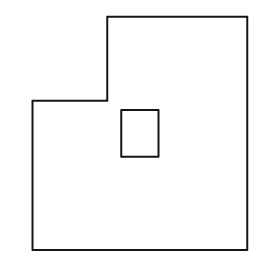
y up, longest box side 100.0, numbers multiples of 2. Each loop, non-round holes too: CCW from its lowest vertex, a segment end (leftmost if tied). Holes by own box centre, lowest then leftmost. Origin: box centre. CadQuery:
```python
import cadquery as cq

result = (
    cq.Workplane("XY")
    .moveTo(-46.0, -50.0)
    .lineTo(46.0, -50.0)
    .lineTo(46.0, 50.0)
    .lineTo(-14.0, 50.0)
    .lineTo(-14.0, 14.0)
    .lineTo(-46.0, 14.0)
    .close()
    .moveTo(-8.0, -10.0)
    .lineTo(8.0, -10.0)
    .lineTo(8.0, 10.0)
    .lineTo(-8.0, 10.0)
    .close()
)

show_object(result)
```